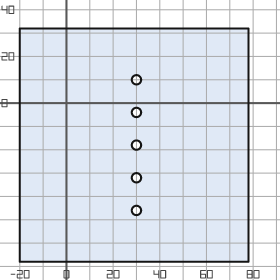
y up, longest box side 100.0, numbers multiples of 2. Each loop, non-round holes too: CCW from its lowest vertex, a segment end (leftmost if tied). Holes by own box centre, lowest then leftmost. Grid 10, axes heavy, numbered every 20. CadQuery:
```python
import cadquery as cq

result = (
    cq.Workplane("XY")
    .moveTo(-20.0, -68.0)
    .lineTo(78.0, -68.0)
    .lineTo(78.0, 32.0)
    .lineTo(-20.0, 32.0)
    .close()
    .moveTo(30.0, -46.0)
    .circle(2.0)
    .moveTo(30.0, -32.0)
    .circle(2.0)
    .moveTo(30.0, -18.0)
    .circle(2.0)
    .moveTo(30.0, -4.0)
    .circle(2.0)
    .moveTo(30.0, 10.0)
    .circle(2.0)
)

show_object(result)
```